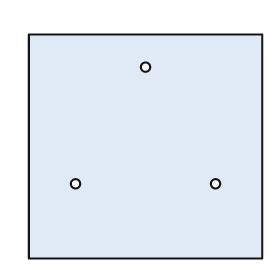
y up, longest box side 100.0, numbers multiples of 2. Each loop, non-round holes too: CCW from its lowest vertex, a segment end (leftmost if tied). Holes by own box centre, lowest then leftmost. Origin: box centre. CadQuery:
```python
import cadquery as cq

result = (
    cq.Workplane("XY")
    .moveTo(-50.0, -48.0)
    .lineTo(50.0, -48.0)
    .lineTo(50.0, 48.0)
    .lineTo(-50.0, 48.0)
    .close()
    .moveTo(-30.0, -16.0)
    .circle(2.0)
    .moveTo(30.0, -16.0)
    .circle(2.0)
    .moveTo(0.0, 34.0)
    .circle(2.0)
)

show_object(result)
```